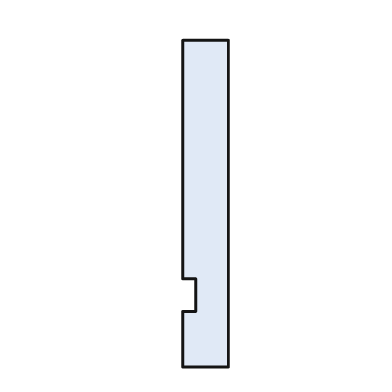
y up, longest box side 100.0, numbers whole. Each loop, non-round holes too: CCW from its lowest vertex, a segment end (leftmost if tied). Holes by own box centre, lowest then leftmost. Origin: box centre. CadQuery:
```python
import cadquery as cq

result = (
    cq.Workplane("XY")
    .moveTo(-7.0, -50.0)
    .lineTo(7.0, -50.0)
    .lineTo(7.0, 50.0)
    .lineTo(-7.0, 50.0)
    .lineTo(-7.0, -23.0)
    .lineTo(-3.0, -23.0)
    .lineTo(-3.0, -33.0)
    .lineTo(-7.0, -33.0)
    .close()
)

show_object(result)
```